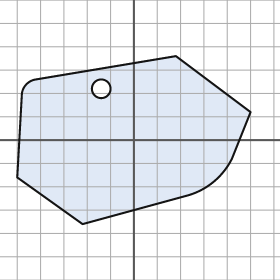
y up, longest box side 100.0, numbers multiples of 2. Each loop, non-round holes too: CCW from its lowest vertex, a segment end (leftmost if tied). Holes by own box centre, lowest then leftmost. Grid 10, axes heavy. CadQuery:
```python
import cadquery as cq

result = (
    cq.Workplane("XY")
    .moveTo(-22.0, -36.0)
    .lineTo(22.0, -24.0)
    .threePointArc((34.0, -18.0), (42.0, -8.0))
    .lineTo(50.0, 12.0)
    .lineTo(18.0, 36.0)
    .lineTo(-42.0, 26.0)
    .threePointArc((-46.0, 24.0), (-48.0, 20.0))
    .lineTo(-50.0, -16.0)
    .close()
    .moveTo(-14.0, 22.0)
    .circle(4.0)
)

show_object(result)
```